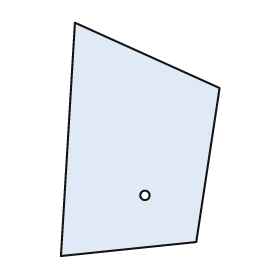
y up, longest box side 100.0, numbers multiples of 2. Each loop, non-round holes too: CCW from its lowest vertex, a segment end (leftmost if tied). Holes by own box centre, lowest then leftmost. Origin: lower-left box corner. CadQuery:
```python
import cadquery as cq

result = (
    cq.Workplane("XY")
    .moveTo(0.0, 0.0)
    .lineTo(58.0, 6.0)
    .lineTo(68.0, 72.0)
    .lineTo(6.0, 100.0)
    .close()
    .moveTo(36.0, 26.0)
    .circle(2.0)
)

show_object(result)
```